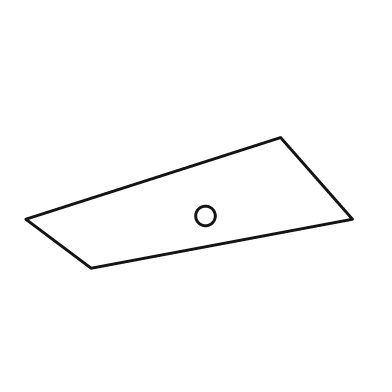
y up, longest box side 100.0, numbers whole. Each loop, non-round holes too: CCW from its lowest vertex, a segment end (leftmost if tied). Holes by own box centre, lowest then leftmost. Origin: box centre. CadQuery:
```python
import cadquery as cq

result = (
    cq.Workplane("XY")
    .moveTo(-30.0, -20.0)
    .lineTo(50.0, -5.0)
    .lineTo(28.0, 20.0)
    .lineTo(-50.0, -5.0)
    .close()
    .moveTo(5.0, -4.0)
    .circle(3.0)
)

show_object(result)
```